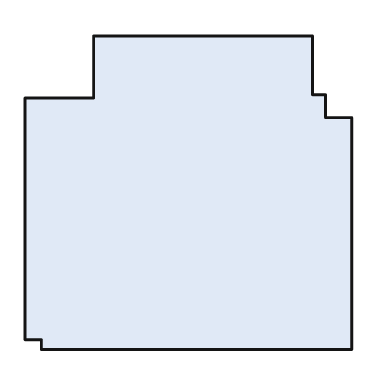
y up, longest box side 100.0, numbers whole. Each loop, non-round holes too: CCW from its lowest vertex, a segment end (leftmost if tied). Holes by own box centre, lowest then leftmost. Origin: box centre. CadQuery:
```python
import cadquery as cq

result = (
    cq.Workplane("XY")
    .moveTo(-45.0, -48.0)
    .lineTo(50.0, -48.0)
    .lineTo(50.0, 23.0)
    .lineTo(42.0, 23.0)
    .lineTo(42.0, 30.0)
    .lineTo(38.0, 30.0)
    .lineTo(38.0, 48.0)
    .lineTo(-29.0, 48.0)
    .lineTo(-29.0, 29.0)
    .lineTo(-50.0, 29.0)
    .lineTo(-50.0, -45.0)
    .lineTo(-45.0, -45.0)
    .close()
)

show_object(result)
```